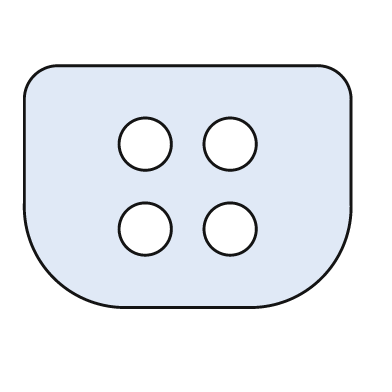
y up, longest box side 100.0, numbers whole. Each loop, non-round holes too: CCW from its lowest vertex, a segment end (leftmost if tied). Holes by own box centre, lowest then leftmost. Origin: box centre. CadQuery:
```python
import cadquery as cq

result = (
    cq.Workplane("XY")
    .moveTo(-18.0, -37.0)
    .lineTo(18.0, -37.0)
    .threePointArc((41.0, -28.0), (50.0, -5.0))
    .lineTo(50.0, 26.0)
    .threePointArc((47.0, 34.0), (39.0, 37.0))
    .lineTo(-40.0, 37.0)
    .threePointArc((-47.0, 34.0), (-50.0, 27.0))
    .lineTo(-50.0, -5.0)
    .threePointArc((-41.0, -28.0), (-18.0, -37.0))
    .close()
    .moveTo(-13.0, -13.0)
    .circle(8.0)
    .moveTo(13.0, -13.0)
    .circle(8.0)
    .moveTo(-13.0, 13.0)
    .circle(8.0)
    .moveTo(13.0, 13.0)
    .circle(8.0)
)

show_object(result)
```